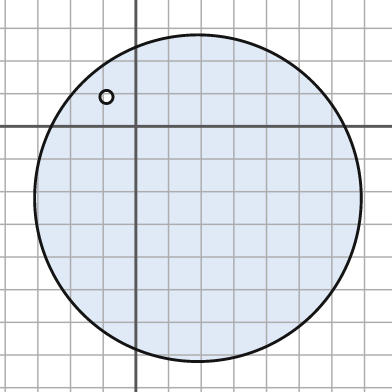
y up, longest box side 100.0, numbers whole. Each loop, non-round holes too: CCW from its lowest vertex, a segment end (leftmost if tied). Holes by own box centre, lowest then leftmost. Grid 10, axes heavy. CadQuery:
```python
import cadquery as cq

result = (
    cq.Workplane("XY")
    .moveTo(19.0, -22.0)
    .circle(50.0)
    .moveTo(-9.0, 9.0)
    .circle(2.0)
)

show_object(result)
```